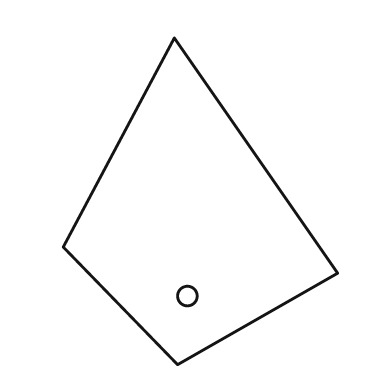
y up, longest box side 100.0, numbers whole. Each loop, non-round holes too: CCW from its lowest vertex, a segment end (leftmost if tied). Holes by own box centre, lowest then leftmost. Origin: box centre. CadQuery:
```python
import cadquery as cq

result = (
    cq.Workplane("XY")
    .moveTo(-7.0, -50.0)
    .lineTo(42.0, -22.0)
    .lineTo(-8.0, 50.0)
    .lineTo(-42.0, -14.0)
    .close()
    .moveTo(-4.0, -29.0)
    .circle(3.0)
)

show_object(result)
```